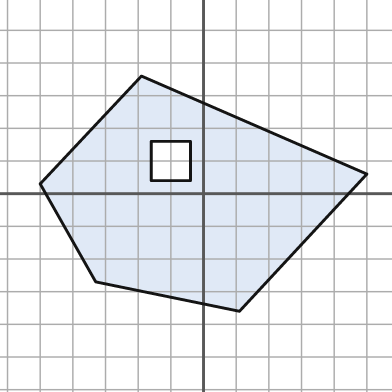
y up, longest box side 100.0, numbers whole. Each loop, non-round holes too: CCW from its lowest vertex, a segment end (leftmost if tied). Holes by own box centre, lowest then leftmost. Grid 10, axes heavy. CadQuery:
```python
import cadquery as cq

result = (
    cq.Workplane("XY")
    .moveTo(11.0, -36.0)
    .lineTo(50.0, 6.0)
    .lineTo(-19.0, 36.0)
    .lineTo(-50.0, 3.0)
    .lineTo(-33.0, -27.0)
    .close()
    .moveTo(-16.0, 4.0)
    .lineTo(-4.0, 4.0)
    .lineTo(-4.0, 16.0)
    .lineTo(-16.0, 16.0)
    .close()
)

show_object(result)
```